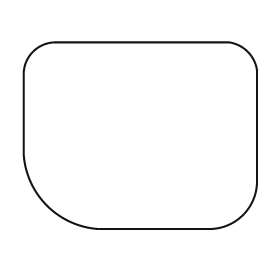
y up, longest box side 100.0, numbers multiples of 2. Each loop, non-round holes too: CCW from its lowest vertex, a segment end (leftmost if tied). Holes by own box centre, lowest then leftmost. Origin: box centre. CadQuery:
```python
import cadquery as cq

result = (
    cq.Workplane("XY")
    .moveTo(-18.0, -40.0)
    .lineTo(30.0, -40.0)
    .threePointArc((44.0, -34.0), (50.0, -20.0))
    .lineTo(50.0, 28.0)
    .threePointArc((46.0, 36.0), (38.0, 40.0))
    .lineTo(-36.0, 40.0)
    .threePointArc((-46.0, 36.0), (-50.0, 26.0))
    .lineTo(-50.0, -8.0)
    .threePointArc((-40.0, -30.0), (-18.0, -40.0))
    .close()
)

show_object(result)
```